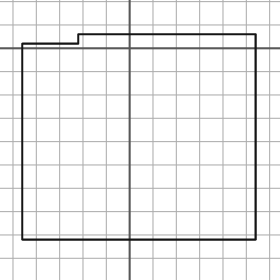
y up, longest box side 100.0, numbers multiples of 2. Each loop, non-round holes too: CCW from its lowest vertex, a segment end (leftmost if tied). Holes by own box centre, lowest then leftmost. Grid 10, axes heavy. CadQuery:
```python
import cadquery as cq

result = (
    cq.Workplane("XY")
    .moveTo(-46.0, -82.0)
    .lineTo(54.0, -82.0)
    .lineTo(54.0, 6.0)
    .lineTo(-22.0, 6.0)
    .lineTo(-22.0, 2.0)
    .lineTo(-46.0, 2.0)
    .close()
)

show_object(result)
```